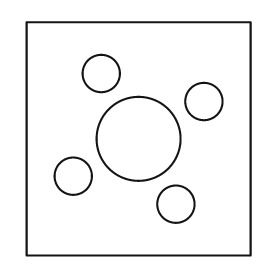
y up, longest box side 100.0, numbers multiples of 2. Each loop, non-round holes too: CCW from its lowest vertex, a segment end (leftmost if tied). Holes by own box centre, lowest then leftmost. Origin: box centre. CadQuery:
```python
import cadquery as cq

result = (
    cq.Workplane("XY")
    .moveTo(-48.0, -50.0)
    .lineTo(48.0, -50.0)
    .lineTo(48.0, 50.0)
    .lineTo(-48.0, 50.0)
    .close()
    .moveTo(16.0, -28.0)
    .circle(8.0)
    .moveTo(-28.0, -16.0)
    .circle(8.0)
    .moveTo(0.0, 0.0)
    .circle(18.0)
    .moveTo(28.0, 16.0)
    .circle(8.0)
    .moveTo(-16.0, 28.0)
    .circle(8.0)
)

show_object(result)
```